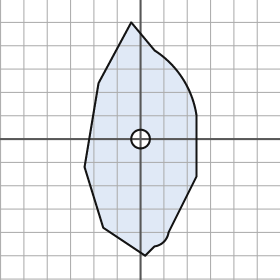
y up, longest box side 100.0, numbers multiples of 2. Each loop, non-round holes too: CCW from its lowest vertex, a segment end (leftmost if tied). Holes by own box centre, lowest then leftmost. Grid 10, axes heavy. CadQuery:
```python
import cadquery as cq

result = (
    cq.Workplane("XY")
    .moveTo(2.0, -50.0)
    .lineTo(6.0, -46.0)
    .threePointArc((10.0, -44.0), (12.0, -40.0))
    .lineTo(24.0, -16.0)
    .lineTo(24.0, 10.0)
    .threePointArc((18.0, 26.0), (6.0, 38.0))
    .lineTo(-4.0, 50.0)
    .lineTo(-18.0, 24.0)
    .lineTo(-24.0, -12.0)
    .lineTo(-16.0, -38.0)
    .close()
    .moveTo(0.0, 0.0)
    .circle(4.0)
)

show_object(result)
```